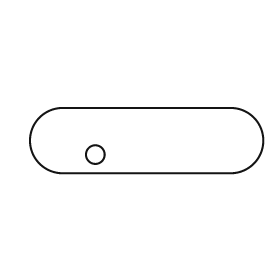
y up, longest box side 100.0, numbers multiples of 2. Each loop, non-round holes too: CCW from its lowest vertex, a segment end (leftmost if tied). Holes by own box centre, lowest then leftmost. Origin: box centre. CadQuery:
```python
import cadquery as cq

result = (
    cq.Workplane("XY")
    .moveTo(-36.0, -14.0)
    .lineTo(36.0, -14.0)
    .threePointArc((50.0, 0.0), (36.0, 14.0))
    .lineTo(-36.0, 14.0)
    .threePointArc((-50.0, 0.0), (-36.0, -14.0))
    .close()
    .moveTo(-22.0, -6.0)
    .circle(4.0)
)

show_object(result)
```